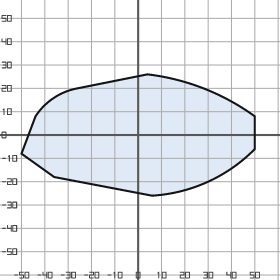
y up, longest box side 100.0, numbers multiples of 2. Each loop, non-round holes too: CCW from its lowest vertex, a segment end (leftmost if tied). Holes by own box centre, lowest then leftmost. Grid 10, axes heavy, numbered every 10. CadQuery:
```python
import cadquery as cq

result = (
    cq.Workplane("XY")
    .moveTo(6.0, -26.0)
    .threePointArc((30.0, -20.0), (50.0, -6.0))
    .lineTo(50.0, 8.0)
    .threePointArc((28.0, 20.0), (4.0, 26.0))
    .lineTo(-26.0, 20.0)
    .threePointArc((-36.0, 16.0), (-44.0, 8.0))
    .lineTo(-50.0, -8.0)
    .lineTo(-36.0, -18.0)
    .close()
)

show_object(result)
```